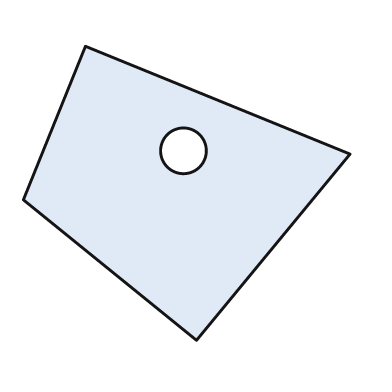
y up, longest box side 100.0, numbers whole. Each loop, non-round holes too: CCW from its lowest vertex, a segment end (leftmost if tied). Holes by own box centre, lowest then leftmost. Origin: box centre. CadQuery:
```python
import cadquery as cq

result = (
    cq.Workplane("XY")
    .moveTo(3.0, -45.0)
    .lineTo(50.0, 12.0)
    .lineTo(-31.0, 45.0)
    .lineTo(-50.0, -2.0)
    .close()
    .moveTo(-1.0, 13.0)
    .circle(7.0)
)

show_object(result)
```